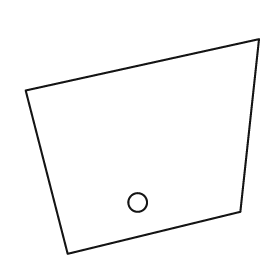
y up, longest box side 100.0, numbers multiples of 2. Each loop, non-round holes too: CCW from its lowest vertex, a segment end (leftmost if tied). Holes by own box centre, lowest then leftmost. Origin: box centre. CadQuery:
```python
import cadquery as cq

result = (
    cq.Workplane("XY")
    .moveTo(-32.0, -46.0)
    .lineTo(42.0, -28.0)
    .lineTo(50.0, 46.0)
    .lineTo(-50.0, 24.0)
    .close()
    .moveTo(-2.0, -24.0)
    .circle(4.0)
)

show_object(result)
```